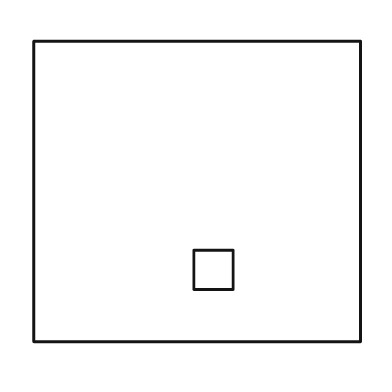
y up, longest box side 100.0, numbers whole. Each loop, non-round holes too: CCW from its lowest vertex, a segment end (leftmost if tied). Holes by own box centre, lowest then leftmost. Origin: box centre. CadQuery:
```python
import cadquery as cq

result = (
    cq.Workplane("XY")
    .moveTo(-50.0, -46.0)
    .lineTo(50.0, -46.0)
    .lineTo(50.0, 46.0)
    .lineTo(-50.0, 46.0)
    .close()
    .moveTo(-1.0, -30.0)
    .lineTo(11.0, -30.0)
    .lineTo(11.0, -18.0)
    .lineTo(-1.0, -18.0)
    .close()
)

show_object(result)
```